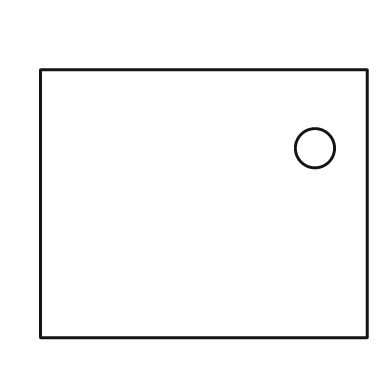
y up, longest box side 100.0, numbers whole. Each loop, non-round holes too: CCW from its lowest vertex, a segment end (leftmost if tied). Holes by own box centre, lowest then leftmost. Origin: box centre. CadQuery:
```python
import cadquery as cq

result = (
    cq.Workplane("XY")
    .moveTo(-50.0, -41.0)
    .lineTo(50.0, -41.0)
    .lineTo(50.0, 41.0)
    .lineTo(-50.0, 41.0)
    .close()
    .moveTo(34.0, 17.0)
    .circle(6.0)
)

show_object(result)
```